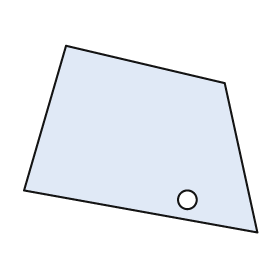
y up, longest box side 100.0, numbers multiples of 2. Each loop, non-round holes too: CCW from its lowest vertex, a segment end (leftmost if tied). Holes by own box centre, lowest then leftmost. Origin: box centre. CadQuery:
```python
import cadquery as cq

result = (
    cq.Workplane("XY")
    .moveTo(50.0, -40.0)
    .lineTo(36.0, 24.0)
    .lineTo(-32.0, 40.0)
    .lineTo(-50.0, -22.0)
    .close()
    .moveTo(20.0, -26.0)
    .circle(4.0)
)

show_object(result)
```